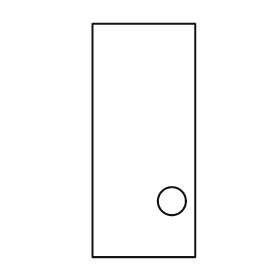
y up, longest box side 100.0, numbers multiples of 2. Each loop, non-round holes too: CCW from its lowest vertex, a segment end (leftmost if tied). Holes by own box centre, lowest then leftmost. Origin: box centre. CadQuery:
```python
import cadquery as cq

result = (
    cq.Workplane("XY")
    .moveTo(-22.0, -50.0)
    .lineTo(22.0, -50.0)
    .lineTo(22.0, 50.0)
    .lineTo(-22.0, 50.0)
    .close()
    .moveTo(12.0, -26.0)
    .circle(6.0)
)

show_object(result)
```